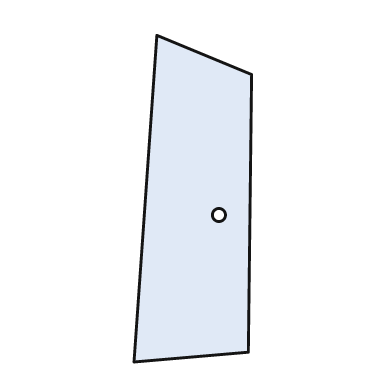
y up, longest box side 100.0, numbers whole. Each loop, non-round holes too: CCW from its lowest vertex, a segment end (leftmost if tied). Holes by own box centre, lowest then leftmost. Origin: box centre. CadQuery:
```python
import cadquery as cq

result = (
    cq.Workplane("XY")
    .moveTo(-18.0, -50.0)
    .lineTo(17.0, -47.0)
    .lineTo(18.0, 38.0)
    .lineTo(-11.0, 50.0)
    .close()
    .moveTo(8.0, -5.0)
    .circle(2.0)
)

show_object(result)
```